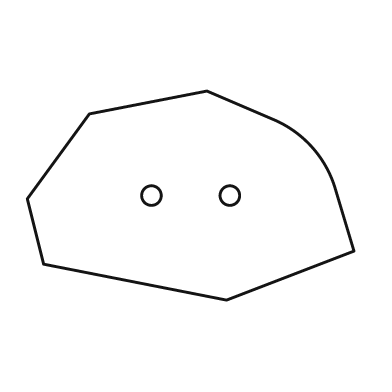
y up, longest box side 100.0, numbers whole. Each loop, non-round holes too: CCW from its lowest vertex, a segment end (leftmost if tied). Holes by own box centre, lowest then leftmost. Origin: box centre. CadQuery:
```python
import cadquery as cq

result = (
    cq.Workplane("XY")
    .moveTo(11.0, -32.0)
    .lineTo(50.0, -17.0)
    .lineTo(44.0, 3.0)
    .threePointArc((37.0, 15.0), (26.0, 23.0))
    .lineTo(5.0, 32.0)
    .lineTo(-31.0, 25.0)
    .lineTo(-50.0, -1.0)
    .lineTo(-45.0, -21.0)
    .close()
    .moveTo(-12.0, 0.0)
    .circle(3.0)
    .moveTo(12.0, 0.0)
    .circle(3.0)
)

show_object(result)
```